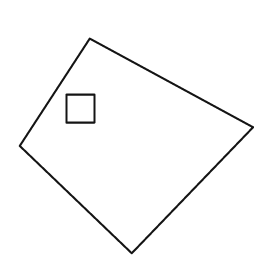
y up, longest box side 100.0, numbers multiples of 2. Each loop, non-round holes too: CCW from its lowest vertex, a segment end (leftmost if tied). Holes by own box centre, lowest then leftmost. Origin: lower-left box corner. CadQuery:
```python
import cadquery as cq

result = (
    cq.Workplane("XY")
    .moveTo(48.0, 0.0)
    .lineTo(100.0, 54.0)
    .lineTo(30.0, 92.0)
    .lineTo(0.0, 46.0)
    .close()
    .moveTo(20.0, 56.0)
    .lineTo(32.0, 56.0)
    .lineTo(32.0, 68.0)
    .lineTo(20.0, 68.0)
    .close()
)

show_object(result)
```